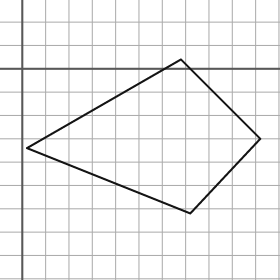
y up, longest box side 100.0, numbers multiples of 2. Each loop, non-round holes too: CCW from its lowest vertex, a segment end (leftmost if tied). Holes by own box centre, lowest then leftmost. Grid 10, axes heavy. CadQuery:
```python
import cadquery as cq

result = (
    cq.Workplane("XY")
    .moveTo(72.0, -62.0)
    .lineTo(102.0, -30.0)
    .lineTo(68.0, 4.0)
    .lineTo(2.0, -34.0)
    .close()
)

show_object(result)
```